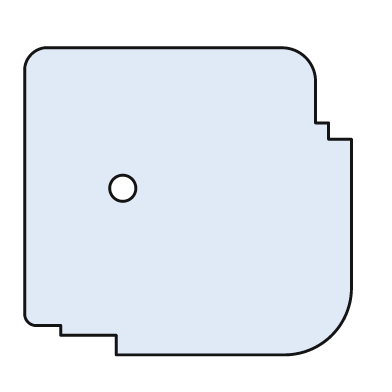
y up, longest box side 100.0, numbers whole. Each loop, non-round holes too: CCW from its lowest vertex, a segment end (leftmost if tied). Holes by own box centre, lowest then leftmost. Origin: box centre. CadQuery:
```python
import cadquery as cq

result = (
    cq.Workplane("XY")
    .moveTo(-22.0, -47.0)
    .lineTo(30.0, -47.0)
    .threePointArc((44.0, -41.0), (50.0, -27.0))
    .lineTo(50.0, 19.0)
    .lineTo(43.0, 19.0)
    .lineTo(43.0, 24.0)
    .lineTo(39.0, 24.0)
    .lineTo(39.0, 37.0)
    .threePointArc((36.0, 44.0), (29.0, 47.0))
    .lineTo(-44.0, 47.0)
    .threePointArc((-48.0, 45.0), (-50.0, 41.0))
    .lineTo(-50.0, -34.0)
    .threePointArc((-49.0, -37.0), (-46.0, -38.0))
    .lineTo(-39.0, -38.0)
    .lineTo(-39.0, -41.0)
    .lineTo(-22.0, -41.0)
    .close()
    .moveTo(-20.0, 4.0)
    .circle(4.0)
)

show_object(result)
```